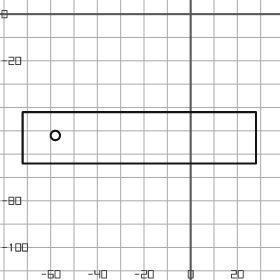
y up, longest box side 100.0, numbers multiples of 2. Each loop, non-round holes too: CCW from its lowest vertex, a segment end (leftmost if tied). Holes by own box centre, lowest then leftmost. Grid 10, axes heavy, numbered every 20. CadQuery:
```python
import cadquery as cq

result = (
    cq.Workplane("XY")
    .moveTo(-72.0, -64.0)
    .lineTo(28.0, -64.0)
    .lineTo(28.0, -42.0)
    .lineTo(-72.0, -42.0)
    .close()
    .moveTo(-58.0, -52.0)
    .circle(2.0)
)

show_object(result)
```